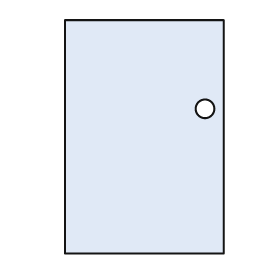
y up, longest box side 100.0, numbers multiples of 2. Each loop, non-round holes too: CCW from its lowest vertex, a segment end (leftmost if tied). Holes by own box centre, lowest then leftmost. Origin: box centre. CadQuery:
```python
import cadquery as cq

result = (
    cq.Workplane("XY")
    .moveTo(-34.0, -50.0)
    .lineTo(34.0, -50.0)
    .lineTo(34.0, 50.0)
    .lineTo(-34.0, 50.0)
    .close()
    .moveTo(26.0, 12.0)
    .circle(4.0)
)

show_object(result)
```